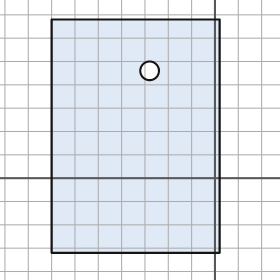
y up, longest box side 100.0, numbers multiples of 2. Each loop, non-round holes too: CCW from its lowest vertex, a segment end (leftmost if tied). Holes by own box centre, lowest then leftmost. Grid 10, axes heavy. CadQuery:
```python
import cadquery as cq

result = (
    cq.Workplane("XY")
    .moveTo(-70.0, -32.0)
    .lineTo(2.0, -32.0)
    .lineTo(2.0, 68.0)
    .lineTo(-70.0, 68.0)
    .close()
    .moveTo(-28.0, 46.0)
    .circle(4.0)
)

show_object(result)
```